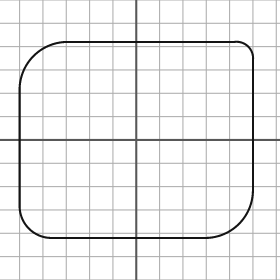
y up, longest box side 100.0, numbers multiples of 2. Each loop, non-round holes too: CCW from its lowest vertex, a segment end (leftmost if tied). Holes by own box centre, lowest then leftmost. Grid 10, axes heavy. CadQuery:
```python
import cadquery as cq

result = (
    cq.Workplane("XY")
    .moveTo(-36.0, -42.0)
    .lineTo(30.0, -42.0)
    .threePointArc((44.0, -36.0), (50.0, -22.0))
    .lineTo(50.0, 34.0)
    .threePointArc((48.0, 40.0), (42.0, 42.0))
    .lineTo(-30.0, 42.0)
    .threePointArc((-44.0, 36.0), (-50.0, 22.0))
    .lineTo(-50.0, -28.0)
    .threePointArc((-46.0, -38.0), (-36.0, -42.0))
    .close()
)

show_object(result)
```